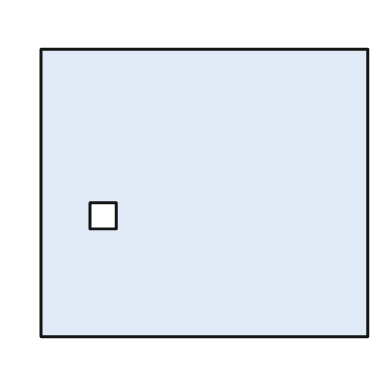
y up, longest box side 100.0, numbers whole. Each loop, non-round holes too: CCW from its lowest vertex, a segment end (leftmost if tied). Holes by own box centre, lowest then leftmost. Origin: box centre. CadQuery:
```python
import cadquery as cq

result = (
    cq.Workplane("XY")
    .moveTo(-50.0, -44.0)
    .lineTo(50.0, -44.0)
    .lineTo(50.0, 44.0)
    .lineTo(-50.0, 44.0)
    .close()
    .moveTo(-35.0, -11.0)
    .lineTo(-27.0, -11.0)
    .lineTo(-27.0, -3.0)
    .lineTo(-35.0, -3.0)
    .close()
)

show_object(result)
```